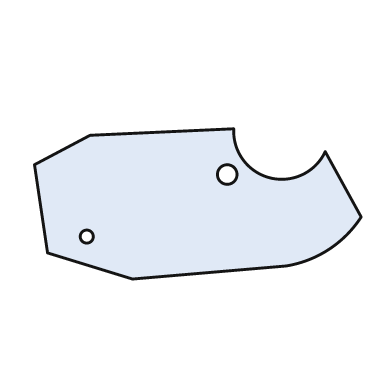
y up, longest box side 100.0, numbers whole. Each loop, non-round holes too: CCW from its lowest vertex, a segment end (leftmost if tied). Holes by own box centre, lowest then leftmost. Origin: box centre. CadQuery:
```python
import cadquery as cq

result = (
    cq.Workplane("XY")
    .moveTo(-20.0, -23.0)
    .lineTo(27.0, -19.0)
    .threePointArc((40.0, -14.0), (50.0, -4.0))
    .lineTo(39.0, 16.0)
    .threePointArc((22.0, 8.0), (11.0, 23.0))
    .lineTo(-33.0, 21.0)
    .lineTo(-50.0, 12.0)
    .lineTo(-46.0, -15.0)
    .close()
    .moveTo(-34.0, -10.0)
    .circle(2.0)
    .moveTo(9.0, 9.0)
    .circle(3.0)
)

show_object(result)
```